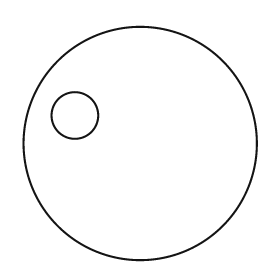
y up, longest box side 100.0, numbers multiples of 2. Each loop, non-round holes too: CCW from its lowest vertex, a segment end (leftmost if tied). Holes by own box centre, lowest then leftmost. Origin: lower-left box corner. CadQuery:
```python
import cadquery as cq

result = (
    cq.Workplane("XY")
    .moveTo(50.0, 50.0)
    .circle(50.0)
    .moveTo(22.0, 62.0)
    .circle(10.0)
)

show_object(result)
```